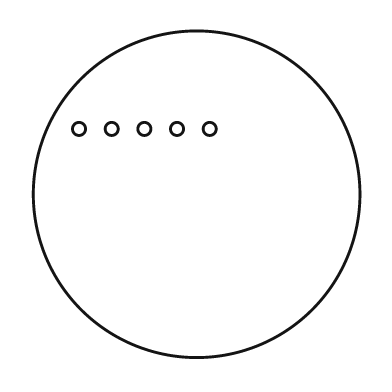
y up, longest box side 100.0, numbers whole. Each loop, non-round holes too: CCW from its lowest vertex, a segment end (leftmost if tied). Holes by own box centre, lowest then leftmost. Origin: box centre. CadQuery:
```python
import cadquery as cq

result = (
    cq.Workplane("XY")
    .moveTo(0.0, 0.0)
    .circle(50.0)
    .moveTo(-36.0, 20.0)
    .circle(2.0)
    .moveTo(-26.0, 20.0)
    .circle(2.0)
    .moveTo(-16.0, 20.0)
    .circle(2.0)
    .moveTo(-6.0, 20.0)
    .circle(2.0)
    .moveTo(4.0, 20.0)
    .circle(2.0)
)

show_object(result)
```